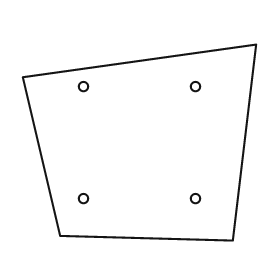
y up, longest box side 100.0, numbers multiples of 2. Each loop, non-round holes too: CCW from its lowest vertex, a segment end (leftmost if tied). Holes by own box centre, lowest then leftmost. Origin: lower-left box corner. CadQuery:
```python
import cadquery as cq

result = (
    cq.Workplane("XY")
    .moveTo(90.0, 0.0)
    .lineTo(100.0, 84.0)
    .lineTo(0.0, 70.0)
    .lineTo(16.0, 2.0)
    .close()
    .moveTo(26.0, 18.0)
    .circle(2.0)
    .moveTo(74.0, 18.0)
    .circle(2.0)
    .moveTo(26.0, 66.0)
    .circle(2.0)
    .moveTo(74.0, 66.0)
    .circle(2.0)
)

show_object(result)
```